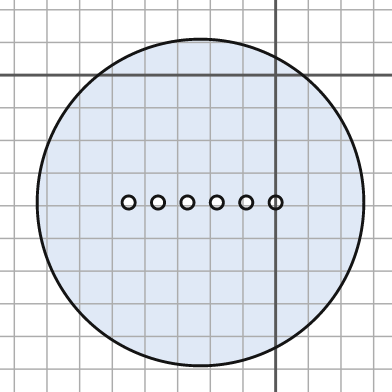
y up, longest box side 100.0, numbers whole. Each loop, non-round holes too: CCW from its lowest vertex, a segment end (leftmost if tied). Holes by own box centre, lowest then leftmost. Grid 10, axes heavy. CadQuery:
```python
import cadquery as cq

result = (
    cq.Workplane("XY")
    .moveTo(-23.0, -39.0)
    .circle(50.0)
    .moveTo(-45.0, -39.0)
    .circle(2.0)
    .moveTo(-36.0, -39.0)
    .circle(2.0)
    .moveTo(-27.0, -39.0)
    .circle(2.0)
    .moveTo(-18.0, -39.0)
    .circle(2.0)
    .moveTo(-9.0, -39.0)
    .circle(2.0)
    .moveTo(0.0, -39.0)
    .circle(2.0)
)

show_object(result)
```